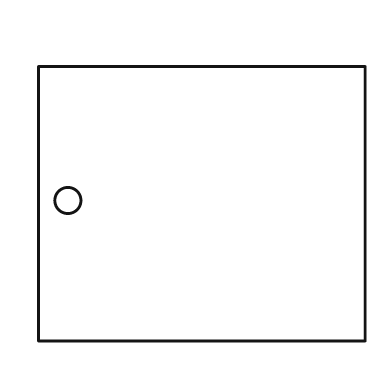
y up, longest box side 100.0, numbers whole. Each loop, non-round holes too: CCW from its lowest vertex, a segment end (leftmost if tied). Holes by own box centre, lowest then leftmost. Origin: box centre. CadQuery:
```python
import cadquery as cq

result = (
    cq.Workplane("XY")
    .moveTo(-50.0, -42.0)
    .lineTo(50.0, -42.0)
    .lineTo(50.0, 42.0)
    .lineTo(-50.0, 42.0)
    .close()
    .moveTo(-41.0, 1.0)
    .circle(4.0)
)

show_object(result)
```